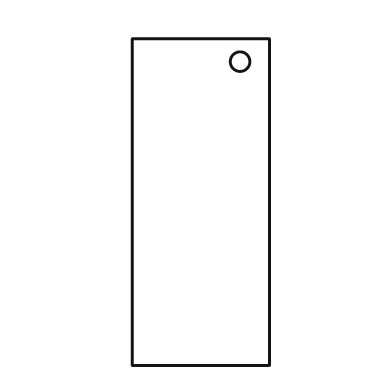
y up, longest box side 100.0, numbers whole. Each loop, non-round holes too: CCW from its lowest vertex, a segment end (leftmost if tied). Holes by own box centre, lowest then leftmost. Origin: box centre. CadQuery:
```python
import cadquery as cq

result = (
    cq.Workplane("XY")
    .moveTo(-21.0, -50.0)
    .lineTo(21.0, -50.0)
    .lineTo(21.0, 50.0)
    .lineTo(-21.0, 50.0)
    .close()
    .moveTo(12.0, 43.0)
    .circle(3.0)
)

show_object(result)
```